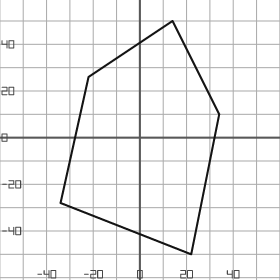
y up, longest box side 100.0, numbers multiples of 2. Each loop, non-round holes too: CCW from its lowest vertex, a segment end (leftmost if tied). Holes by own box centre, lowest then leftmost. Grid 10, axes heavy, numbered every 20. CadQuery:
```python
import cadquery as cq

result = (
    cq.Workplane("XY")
    .moveTo(22.0, -50.0)
    .lineTo(34.0, 10.0)
    .lineTo(14.0, 50.0)
    .lineTo(-22.0, 26.0)
    .lineTo(-34.0, -28.0)
    .close()
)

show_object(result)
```